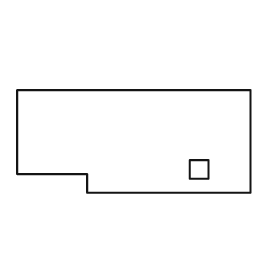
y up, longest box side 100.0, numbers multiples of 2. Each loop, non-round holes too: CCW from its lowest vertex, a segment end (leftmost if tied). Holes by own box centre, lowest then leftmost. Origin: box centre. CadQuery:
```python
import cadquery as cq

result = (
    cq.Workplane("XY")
    .moveTo(-20.0, -22.0)
    .lineTo(50.0, -22.0)
    .lineTo(50.0, 22.0)
    .lineTo(-50.0, 22.0)
    .lineTo(-50.0, -14.0)
    .lineTo(-20.0, -14.0)
    .close()
    .moveTo(24.0, -16.0)
    .lineTo(32.0, -16.0)
    .lineTo(32.0, -8.0)
    .lineTo(24.0, -8.0)
    .close()
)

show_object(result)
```